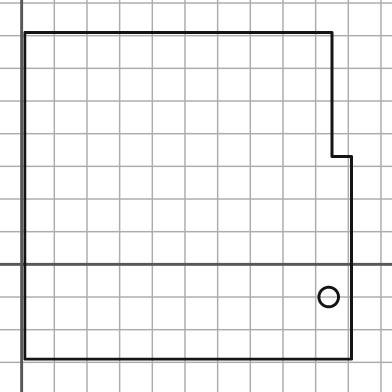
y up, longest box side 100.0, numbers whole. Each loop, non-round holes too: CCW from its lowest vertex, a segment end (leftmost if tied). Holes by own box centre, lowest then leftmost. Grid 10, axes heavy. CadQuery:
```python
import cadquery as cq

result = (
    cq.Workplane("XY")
    .moveTo(1.0, -29.0)
    .lineTo(101.0, -29.0)
    .lineTo(101.0, 33.0)
    .lineTo(95.0, 33.0)
    .lineTo(95.0, 71.0)
    .lineTo(1.0, 71.0)
    .close()
    .moveTo(94.0, -10.0)
    .circle(3.0)
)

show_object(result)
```